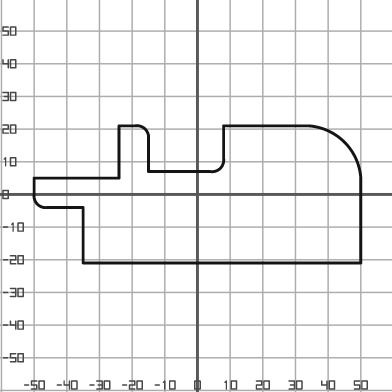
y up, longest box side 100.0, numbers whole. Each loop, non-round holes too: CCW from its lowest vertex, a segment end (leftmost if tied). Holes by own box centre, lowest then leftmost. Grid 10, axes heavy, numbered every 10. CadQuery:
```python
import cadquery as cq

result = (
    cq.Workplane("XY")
    .moveTo(-35.0, -21.0)
    .lineTo(50.0, -21.0)
    .lineTo(50.0, 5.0)
    .threePointArc((45.0, 16.0), (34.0, 21.0))
    .lineTo(8.0, 21.0)
    .lineTo(8.0, 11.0)
    .threePointArc((7.0, 8.0), (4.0, 7.0))
    .lineTo(-15.0, 7.0)
    .lineTo(-15.0, 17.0)
    .threePointArc((-16.0, 20.0), (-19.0, 21.0))
    .lineTo(-24.0, 21.0)
    .lineTo(-24.0, 5.0)
    .lineTo(-50.0, 5.0)
    .lineTo(-50.0, 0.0)
    .threePointArc((-49.0, -3.0), (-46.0, -4.0))
    .lineTo(-35.0, -4.0)
    .close()
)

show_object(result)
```